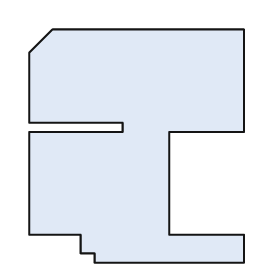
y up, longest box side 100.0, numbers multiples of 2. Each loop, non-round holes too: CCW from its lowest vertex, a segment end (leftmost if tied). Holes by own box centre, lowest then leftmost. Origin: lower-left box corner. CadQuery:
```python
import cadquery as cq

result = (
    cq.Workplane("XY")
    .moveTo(28.0, 0.0)
    .lineTo(92.0, 0.0)
    .lineTo(92.0, 12.0)
    .lineTo(60.0, 12.0)
    .lineTo(60.0, 56.0)
    .lineTo(92.0, 56.0)
    .lineTo(92.0, 100.0)
    .lineTo(10.0, 100.0)
    .lineTo(0.0, 90.0)
    .lineTo(0.0, 60.0)
    .lineTo(40.0, 60.0)
    .lineTo(40.0, 56.0)
    .lineTo(0.0, 56.0)
    .lineTo(0.0, 12.0)
    .lineTo(22.0, 12.0)
    .lineTo(22.0, 4.0)
    .lineTo(28.0, 4.0)
    .close()
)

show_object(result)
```